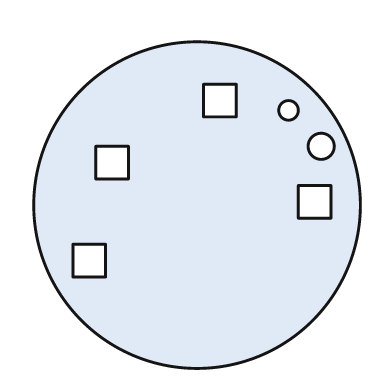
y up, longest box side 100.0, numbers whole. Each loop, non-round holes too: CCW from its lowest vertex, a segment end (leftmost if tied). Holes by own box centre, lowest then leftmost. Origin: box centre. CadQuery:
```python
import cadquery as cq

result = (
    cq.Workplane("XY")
    .moveTo(0.0, 0.0)
    .circle(50.0)
    .moveTo(-38.0, -22.0)
    .lineTo(-28.0, -22.0)
    .lineTo(-28.0, -12.0)
    .lineTo(-38.0, -12.0)
    .close()
    .moveTo(31.0, -4.0)
    .lineTo(41.0, -4.0)
    .lineTo(41.0, 6.0)
    .lineTo(31.0, 6.0)
    .close()
    .moveTo(-31.0, 8.0)
    .lineTo(-21.0, 8.0)
    .lineTo(-21.0, 18.0)
    .lineTo(-31.0, 18.0)
    .close()
    .moveTo(38.0, 18.0)
    .circle(4.0)
    .moveTo(28.0, 29.0)
    .circle(3.0)
    .moveTo(2.0, 27.0)
    .lineTo(12.0, 27.0)
    .lineTo(12.0, 37.0)
    .lineTo(2.0, 37.0)
    .close()
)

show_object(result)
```